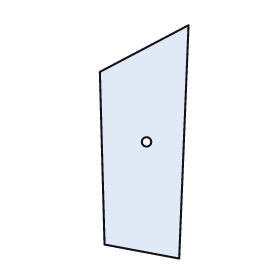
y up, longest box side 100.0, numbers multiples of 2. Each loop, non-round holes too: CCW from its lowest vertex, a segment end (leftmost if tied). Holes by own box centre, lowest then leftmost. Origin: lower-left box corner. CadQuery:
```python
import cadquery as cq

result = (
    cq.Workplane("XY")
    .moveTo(34.0, 0.0)
    .lineTo(38.0, 100.0)
    .lineTo(0.0, 80.0)
    .lineTo(2.0, 6.0)
    .close()
    .moveTo(20.0, 50.0)
    .circle(2.0)
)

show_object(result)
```